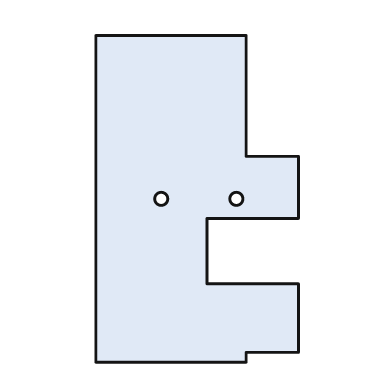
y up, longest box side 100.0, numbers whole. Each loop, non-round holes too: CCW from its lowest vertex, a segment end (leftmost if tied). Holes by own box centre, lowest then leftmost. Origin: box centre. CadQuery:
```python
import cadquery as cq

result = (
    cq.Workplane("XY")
    .moveTo(-31.0, -50.0)
    .lineTo(15.0, -50.0)
    .lineTo(15.0, -47.0)
    .lineTo(31.0, -47.0)
    .lineTo(31.0, -26.0)
    .lineTo(3.0, -26.0)
    .lineTo(3.0, -6.0)
    .lineTo(31.0, -6.0)
    .lineTo(31.0, 13.0)
    .lineTo(15.0, 13.0)
    .lineTo(15.0, 50.0)
    .lineTo(-31.0, 50.0)
    .close()
    .moveTo(-11.0, 0.0)
    .circle(2.0)
    .moveTo(12.0, 0.0)
    .circle(2.0)
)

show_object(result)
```